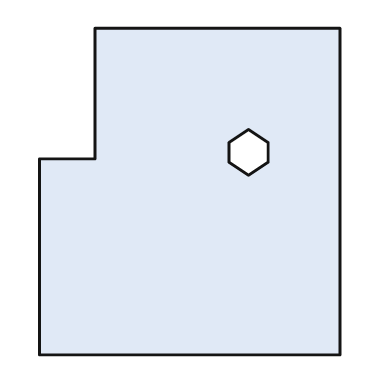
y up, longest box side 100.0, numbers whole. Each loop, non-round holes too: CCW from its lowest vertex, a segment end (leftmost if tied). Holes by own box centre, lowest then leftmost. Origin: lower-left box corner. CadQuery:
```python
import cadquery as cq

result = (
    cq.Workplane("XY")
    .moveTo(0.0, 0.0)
    .lineTo(92.0, 0.0)
    .lineTo(92.0, 100.0)
    .lineTo(17.0, 100.0)
    .lineTo(17.0, 60.0)
    .lineTo(0.0, 60.0)
    .close()
    .moveTo(64.0, 55.0)
    .lineTo(70.0, 59.0)
    .lineTo(70.0, 65.0)
    .lineTo(64.0, 69.0)
    .lineTo(58.0, 65.0)
    .lineTo(58.0, 59.0)
    .close()
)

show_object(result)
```